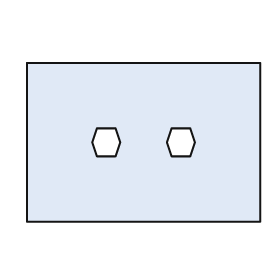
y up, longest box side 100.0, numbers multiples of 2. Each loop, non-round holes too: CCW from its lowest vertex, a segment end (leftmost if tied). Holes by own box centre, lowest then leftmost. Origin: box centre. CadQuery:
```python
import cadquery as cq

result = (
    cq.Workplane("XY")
    .moveTo(-50.0, -34.0)
    .lineTo(50.0, -34.0)
    .lineTo(50.0, 34.0)
    .lineTo(-50.0, 34.0)
    .close()
    .moveTo(-20.0, -6.0)
    .lineTo(-12.0, -6.0)
    .lineTo(-10.0, 0.0)
    .lineTo(-12.0, 6.0)
    .lineTo(-20.0, 6.0)
    .lineTo(-22.0, 0.0)
    .close()
    .moveTo(12.0, -6.0)
    .lineTo(20.0, -6.0)
    .lineTo(22.0, 0.0)
    .lineTo(20.0, 6.0)
    .lineTo(12.0, 6.0)
    .lineTo(10.0, 0.0)
    .close()
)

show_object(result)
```